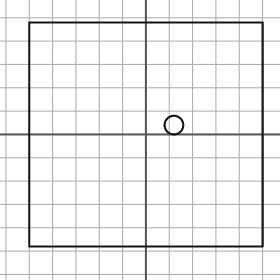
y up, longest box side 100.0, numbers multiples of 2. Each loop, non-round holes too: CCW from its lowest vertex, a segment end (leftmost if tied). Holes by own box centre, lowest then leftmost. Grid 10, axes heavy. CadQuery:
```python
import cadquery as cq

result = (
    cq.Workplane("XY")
    .moveTo(-50.0, -48.0)
    .lineTo(50.0, -48.0)
    .lineTo(50.0, 48.0)
    .lineTo(-50.0, 48.0)
    .close()
    .moveTo(12.0, 4.0)
    .circle(4.0)
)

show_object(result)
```